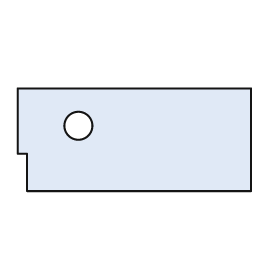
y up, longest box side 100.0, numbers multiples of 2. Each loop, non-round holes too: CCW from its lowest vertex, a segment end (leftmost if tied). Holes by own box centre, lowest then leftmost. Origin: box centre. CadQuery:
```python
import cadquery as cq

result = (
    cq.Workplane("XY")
    .moveTo(-46.0, -22.0)
    .lineTo(50.0, -22.0)
    .lineTo(50.0, 22.0)
    .lineTo(-50.0, 22.0)
    .lineTo(-50.0, -6.0)
    .lineTo(-46.0, -6.0)
    .close()
    .moveTo(-24.0, 6.0)
    .circle(6.0)
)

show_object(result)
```